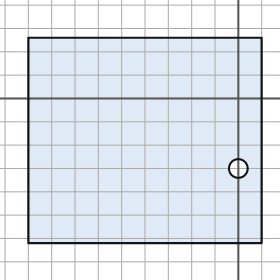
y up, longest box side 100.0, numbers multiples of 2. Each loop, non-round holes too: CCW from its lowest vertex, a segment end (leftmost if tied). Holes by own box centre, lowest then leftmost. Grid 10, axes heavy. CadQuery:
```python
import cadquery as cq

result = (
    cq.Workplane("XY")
    .moveTo(-90.0, -62.0)
    .lineTo(10.0, -62.0)
    .lineTo(10.0, 26.0)
    .lineTo(-90.0, 26.0)
    .close()
    .moveTo(0.0, -30.0)
    .circle(4.0)
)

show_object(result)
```